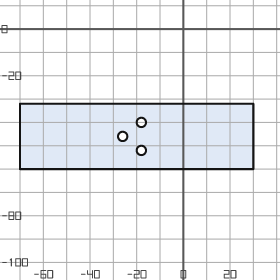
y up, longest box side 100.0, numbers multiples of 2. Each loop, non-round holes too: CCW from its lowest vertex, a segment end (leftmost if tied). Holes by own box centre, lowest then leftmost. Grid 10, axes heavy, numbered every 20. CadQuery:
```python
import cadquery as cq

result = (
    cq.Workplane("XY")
    .moveTo(-70.0, -60.0)
    .lineTo(30.0, -60.0)
    .lineTo(30.0, -32.0)
    .lineTo(-70.0, -32.0)
    .close()
    .moveTo(-18.0, -52.0)
    .circle(2.0)
    .moveTo(-26.0, -46.0)
    .circle(2.0)
    .moveTo(-18.0, -40.0)
    .circle(2.0)
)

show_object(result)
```